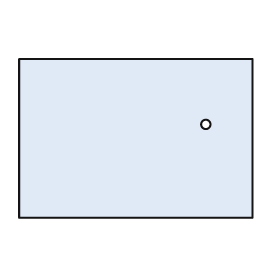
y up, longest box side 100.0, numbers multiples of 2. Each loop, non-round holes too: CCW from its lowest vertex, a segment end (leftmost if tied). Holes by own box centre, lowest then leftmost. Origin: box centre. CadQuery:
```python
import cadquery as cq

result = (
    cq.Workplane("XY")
    .moveTo(-50.0, -34.0)
    .lineTo(50.0, -34.0)
    .lineTo(50.0, 34.0)
    .lineTo(-50.0, 34.0)
    .close()
    .moveTo(30.0, 6.0)
    .circle(2.0)
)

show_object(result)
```